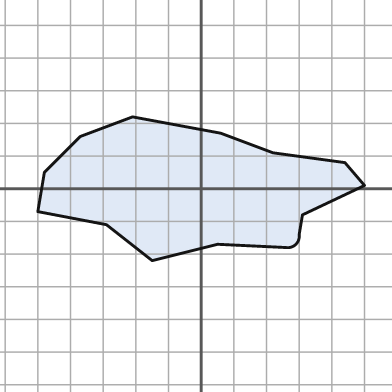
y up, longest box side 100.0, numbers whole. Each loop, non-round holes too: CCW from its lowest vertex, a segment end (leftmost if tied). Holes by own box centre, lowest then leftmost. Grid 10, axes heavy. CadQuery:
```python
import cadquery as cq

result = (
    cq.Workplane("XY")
    .moveTo(-15.0, -22.0)
    .lineTo(5.0, -17.0)
    .lineTo(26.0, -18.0)
    .threePointArc((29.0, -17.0), (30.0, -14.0))
    .lineTo(31.0, -8.0)
    .lineTo(50.0, 1.0)
    .lineTo(44.0, 8.0)
    .lineTo(22.0, 11.0)
    .lineTo(6.0, 17.0)
    .lineTo(-21.0, 22.0)
    .lineTo(-37.0, 16.0)
    .lineTo(-48.0, 5.0)
    .lineTo(-50.0, -7.0)
    .lineTo(-29.0, -11.0)
    .close()
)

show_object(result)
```